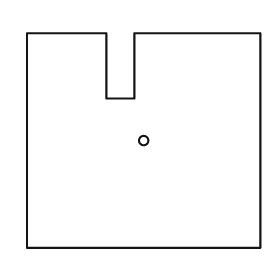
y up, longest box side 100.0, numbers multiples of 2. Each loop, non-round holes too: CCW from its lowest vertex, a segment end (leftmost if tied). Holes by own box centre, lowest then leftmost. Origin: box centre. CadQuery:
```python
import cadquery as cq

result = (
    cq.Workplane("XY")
    .moveTo(-50.0, -46.0)
    .lineTo(50.0, -46.0)
    .lineTo(50.0, 46.0)
    .lineTo(-4.0, 46.0)
    .lineTo(-4.0, 18.0)
    .lineTo(-16.0, 18.0)
    .lineTo(-16.0, 46.0)
    .lineTo(-50.0, 46.0)
    .close()
    .moveTo(0.0, 0.0)
    .circle(2.0)
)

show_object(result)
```